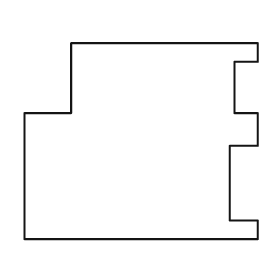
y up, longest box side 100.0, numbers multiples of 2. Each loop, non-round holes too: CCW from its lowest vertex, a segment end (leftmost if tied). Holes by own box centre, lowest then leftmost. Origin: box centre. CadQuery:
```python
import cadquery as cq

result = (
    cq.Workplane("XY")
    .moveTo(-50.0, -42.0)
    .lineTo(50.0, -42.0)
    .lineTo(50.0, -34.0)
    .lineTo(38.0, -34.0)
    .lineTo(38.0, -2.0)
    .lineTo(50.0, -2.0)
    .lineTo(50.0, 12.0)
    .lineTo(40.0, 12.0)
    .lineTo(40.0, 34.0)
    .lineTo(50.0, 34.0)
    .lineTo(50.0, 42.0)
    .lineTo(-30.0, 42.0)
    .lineTo(-30.0, 12.0)
    .lineTo(-50.0, 12.0)
    .close()
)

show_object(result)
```